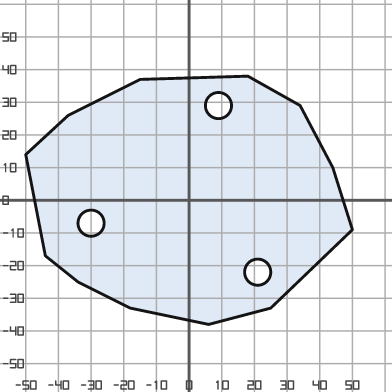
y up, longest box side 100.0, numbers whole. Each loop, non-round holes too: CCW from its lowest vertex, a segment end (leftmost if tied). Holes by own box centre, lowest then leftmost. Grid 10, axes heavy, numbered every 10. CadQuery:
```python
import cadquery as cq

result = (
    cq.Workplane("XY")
    .moveTo(6.0, -38.0)
    .lineTo(25.0, -33.0)
    .lineTo(50.0, -9.0)
    .lineTo(44.0, 10.0)
    .lineTo(34.0, 29.0)
    .lineTo(18.0, 38.0)
    .lineTo(-15.0, 37.0)
    .lineTo(-37.0, 26.0)
    .lineTo(-50.0, 14.0)
    .lineTo(-44.0, -17.0)
    .lineTo(-34.0, -25.0)
    .lineTo(-18.0, -33.0)
    .close()
    .moveTo(21.0, -22.0)
    .circle(4.0)
    .moveTo(-30.0, -7.0)
    .circle(4.0)
    .moveTo(9.0, 29.0)
    .circle(4.0)
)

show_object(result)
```